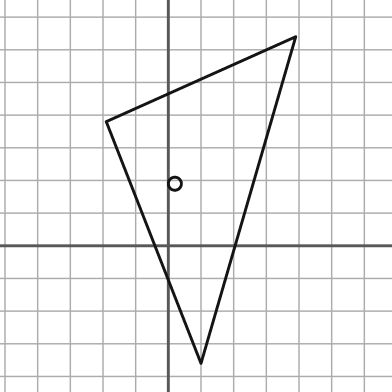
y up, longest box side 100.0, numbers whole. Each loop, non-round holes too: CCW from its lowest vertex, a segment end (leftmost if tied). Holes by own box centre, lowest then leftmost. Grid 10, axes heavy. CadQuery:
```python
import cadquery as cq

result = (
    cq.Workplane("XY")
    .moveTo(10.0, -36.0)
    .lineTo(39.0, 64.0)
    .lineTo(-19.0, 38.0)
    .close()
    .moveTo(2.0, 19.0)
    .circle(2.0)
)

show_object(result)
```